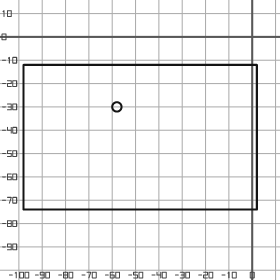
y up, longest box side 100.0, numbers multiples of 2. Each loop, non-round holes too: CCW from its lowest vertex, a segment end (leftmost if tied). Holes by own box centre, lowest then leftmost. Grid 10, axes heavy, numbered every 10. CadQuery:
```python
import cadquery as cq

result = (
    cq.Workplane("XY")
    .moveTo(-98.0, -74.0)
    .lineTo(2.0, -74.0)
    .lineTo(2.0, -12.0)
    .lineTo(-98.0, -12.0)
    .close()
    .moveTo(-58.0, -30.0)
    .circle(2.0)
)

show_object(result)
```